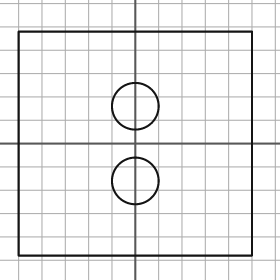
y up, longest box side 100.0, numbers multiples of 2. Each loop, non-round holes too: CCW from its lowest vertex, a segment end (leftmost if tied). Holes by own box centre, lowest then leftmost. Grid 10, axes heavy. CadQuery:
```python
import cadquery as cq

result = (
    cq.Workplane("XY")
    .moveTo(-50.0, -48.0)
    .lineTo(50.0, -48.0)
    .lineTo(50.0, 48.0)
    .lineTo(-50.0, 48.0)
    .close()
    .moveTo(0.0, -16.0)
    .circle(10.0)
    .moveTo(0.0, 16.0)
    .circle(10.0)
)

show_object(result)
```